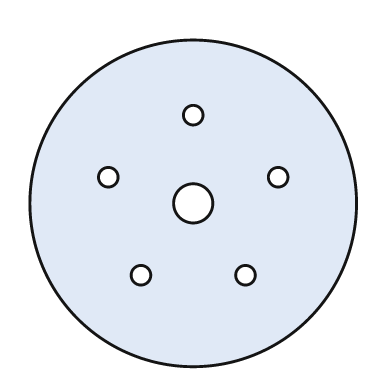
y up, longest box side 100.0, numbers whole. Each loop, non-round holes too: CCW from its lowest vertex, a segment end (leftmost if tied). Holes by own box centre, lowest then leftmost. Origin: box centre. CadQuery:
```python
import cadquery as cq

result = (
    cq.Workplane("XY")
    .moveTo(0.0, 0.0)
    .circle(50.0)
    .moveTo(-16.0, -22.0)
    .circle(3.0)
    .moveTo(16.0, -22.0)
    .circle(3.0)
    .moveTo(0.0, 0.0)
    .circle(6.0)
    .moveTo(-26.0, 8.0)
    .circle(3.0)
    .moveTo(26.0, 8.0)
    .circle(3.0)
    .moveTo(0.0, 27.0)
    .circle(3.0)
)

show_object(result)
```